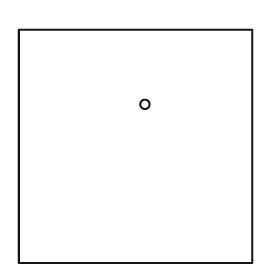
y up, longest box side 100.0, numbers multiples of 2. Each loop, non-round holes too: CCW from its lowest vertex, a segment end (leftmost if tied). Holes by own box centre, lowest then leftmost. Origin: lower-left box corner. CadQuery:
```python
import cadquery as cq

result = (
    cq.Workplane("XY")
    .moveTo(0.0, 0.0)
    .lineTo(100.0, 0.0)
    .lineTo(100.0, 100.0)
    .lineTo(0.0, 100.0)
    .close()
    .moveTo(54.0, 68.0)
    .circle(2.0)
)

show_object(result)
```